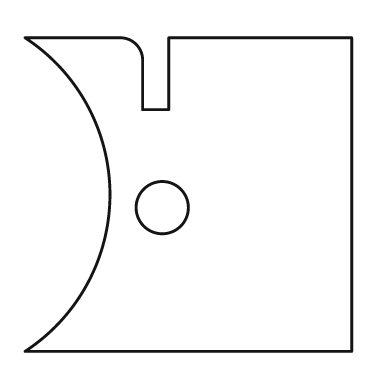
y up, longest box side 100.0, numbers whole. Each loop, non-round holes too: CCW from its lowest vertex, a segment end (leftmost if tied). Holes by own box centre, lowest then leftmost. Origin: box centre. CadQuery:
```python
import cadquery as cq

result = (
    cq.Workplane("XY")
    .moveTo(-50.0, -48.0)
    .lineTo(50.0, -48.0)
    .lineTo(50.0, 48.0)
    .lineTo(-6.0, 48.0)
    .lineTo(-6.0, 26.0)
    .lineTo(-14.0, 26.0)
    .lineTo(-14.0, 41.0)
    .threePointArc((-16.0, 46.0), (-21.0, 48.0))
    .lineTo(-50.0, 48.0)
    .threePointArc((-24.0, 0.0), (-50.0, -48.0))
    .close()
    .moveTo(-8.0, -4.0)
    .circle(8.0)
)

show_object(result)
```